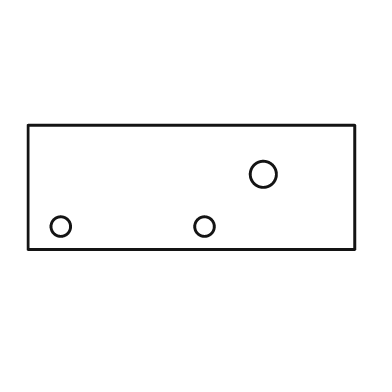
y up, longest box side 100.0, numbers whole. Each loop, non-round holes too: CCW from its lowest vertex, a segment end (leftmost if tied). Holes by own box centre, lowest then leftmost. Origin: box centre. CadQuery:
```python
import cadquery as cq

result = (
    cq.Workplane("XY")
    .moveTo(-50.0, -19.0)
    .lineTo(50.0, -19.0)
    .lineTo(50.0, 19.0)
    .lineTo(-50.0, 19.0)
    .close()
    .moveTo(-40.0, -12.0)
    .circle(3.0)
    .moveTo(4.0, -12.0)
    .circle(3.0)
    .moveTo(22.0, 4.0)
    .circle(4.0)
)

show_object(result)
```